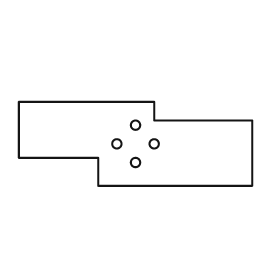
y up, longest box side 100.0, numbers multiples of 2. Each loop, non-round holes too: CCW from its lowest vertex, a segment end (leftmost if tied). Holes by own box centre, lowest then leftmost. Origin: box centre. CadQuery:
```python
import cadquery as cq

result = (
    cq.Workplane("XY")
    .moveTo(-16.0, -18.0)
    .lineTo(50.0, -18.0)
    .lineTo(50.0, 10.0)
    .lineTo(8.0, 10.0)
    .lineTo(8.0, 18.0)
    .lineTo(-50.0, 18.0)
    .lineTo(-50.0, -6.0)
    .lineTo(-16.0, -6.0)
    .close()
    .moveTo(0.0, -8.0)
    .circle(2.0)
    .moveTo(-8.0, 0.0)
    .circle(2.0)
    .moveTo(8.0, 0.0)
    .circle(2.0)
    .moveTo(0.0, 8.0)
    .circle(2.0)
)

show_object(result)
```